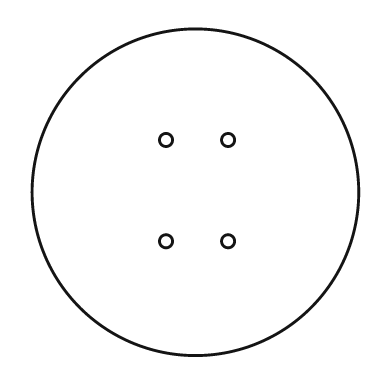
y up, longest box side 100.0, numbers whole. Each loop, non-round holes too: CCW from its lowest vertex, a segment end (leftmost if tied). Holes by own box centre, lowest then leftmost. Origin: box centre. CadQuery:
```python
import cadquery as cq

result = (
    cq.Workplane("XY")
    .moveTo(0.0, 0.0)
    .circle(50.0)
    .moveTo(-9.0, -15.0)
    .circle(2.0)
    .moveTo(10.0, -15.0)
    .circle(2.0)
    .moveTo(-9.0, 16.0)
    .circle(2.0)
    .moveTo(10.0, 16.0)
    .circle(2.0)
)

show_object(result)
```